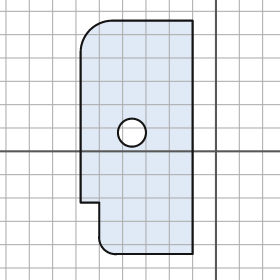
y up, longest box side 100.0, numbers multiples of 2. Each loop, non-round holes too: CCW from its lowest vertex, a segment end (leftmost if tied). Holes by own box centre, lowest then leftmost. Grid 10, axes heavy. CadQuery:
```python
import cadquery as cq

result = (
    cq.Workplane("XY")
    .moveTo(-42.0, -44.0)
    .lineTo(-10.0, -44.0)
    .lineTo(-10.0, 56.0)
    .lineTo(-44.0, 56.0)
    .threePointArc((-54.0, 52.0), (-58.0, 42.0))
    .lineTo(-58.0, -22.0)
    .lineTo(-50.0, -22.0)
    .lineTo(-50.0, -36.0)
    .threePointArc((-48.0, -42.0), (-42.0, -44.0))
    .close()
    .moveTo(-36.0, 8.0)
    .circle(6.0)
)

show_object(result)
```